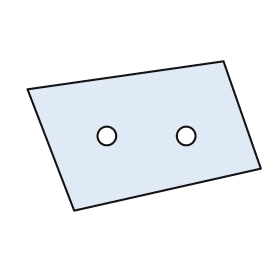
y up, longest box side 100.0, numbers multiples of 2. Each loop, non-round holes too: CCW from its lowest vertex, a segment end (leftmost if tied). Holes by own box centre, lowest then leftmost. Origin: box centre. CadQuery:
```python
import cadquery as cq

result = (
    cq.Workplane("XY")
    .moveTo(-30.0, -32.0)
    .lineTo(50.0, -14.0)
    .lineTo(34.0, 32.0)
    .lineTo(-50.0, 20.0)
    .close()
    .moveTo(-16.0, 0.0)
    .circle(4.0)
    .moveTo(18.0, 0.0)
    .circle(4.0)
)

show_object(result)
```